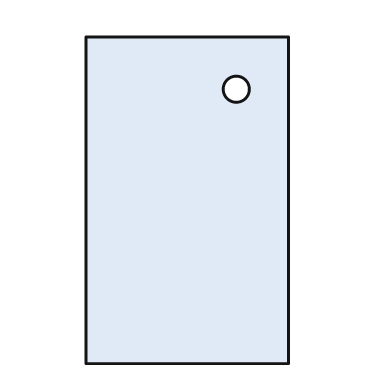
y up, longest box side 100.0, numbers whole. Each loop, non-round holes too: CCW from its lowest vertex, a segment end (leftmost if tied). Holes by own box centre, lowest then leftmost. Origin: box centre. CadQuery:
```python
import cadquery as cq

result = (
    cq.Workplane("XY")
    .moveTo(-31.0, -50.0)
    .lineTo(31.0, -50.0)
    .lineTo(31.0, 50.0)
    .lineTo(-31.0, 50.0)
    .close()
    .moveTo(15.0, 34.0)
    .circle(4.0)
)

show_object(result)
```